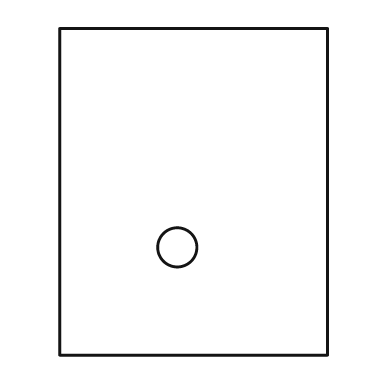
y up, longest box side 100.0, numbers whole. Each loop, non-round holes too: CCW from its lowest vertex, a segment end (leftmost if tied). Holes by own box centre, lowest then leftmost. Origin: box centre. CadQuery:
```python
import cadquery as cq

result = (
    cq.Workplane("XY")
    .moveTo(-41.0, -50.0)
    .lineTo(41.0, -50.0)
    .lineTo(41.0, 50.0)
    .lineTo(-41.0, 50.0)
    .close()
    .moveTo(-5.0, -17.0)
    .circle(6.0)
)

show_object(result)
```